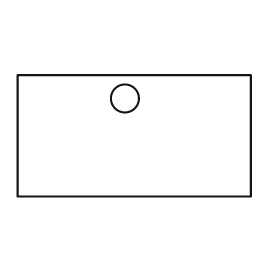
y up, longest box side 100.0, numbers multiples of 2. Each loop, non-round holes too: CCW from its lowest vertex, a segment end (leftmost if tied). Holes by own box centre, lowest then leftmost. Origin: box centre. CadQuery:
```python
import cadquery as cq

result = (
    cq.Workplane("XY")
    .moveTo(-50.0, -26.0)
    .lineTo(50.0, -26.0)
    .lineTo(50.0, 26.0)
    .lineTo(-50.0, 26.0)
    .close()
    .moveTo(-4.0, 16.0)
    .circle(6.0)
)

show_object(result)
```